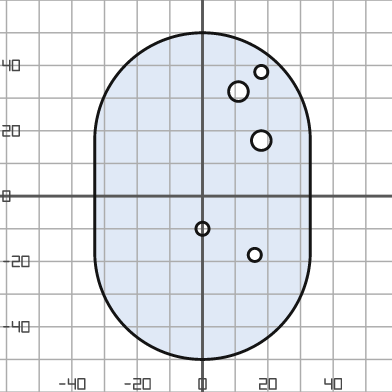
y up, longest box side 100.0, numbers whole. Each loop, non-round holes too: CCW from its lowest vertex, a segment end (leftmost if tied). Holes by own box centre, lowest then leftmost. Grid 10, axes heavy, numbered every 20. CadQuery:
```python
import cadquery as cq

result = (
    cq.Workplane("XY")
    .moveTo(-33.0, -17.0)
    .threePointArc((0.0, -50.0), (33.0, -17.0))
    .lineTo(33.0, 17.0)
    .threePointArc((0.0, 50.0), (-33.0, 17.0))
    .close()
    .moveTo(16.0, -18.0)
    .circle(2.0)
    .moveTo(0.0, -10.0)
    .circle(2.0)
    .moveTo(18.0, 17.0)
    .circle(3.0)
    .moveTo(11.0, 32.0)
    .circle(3.0)
    .moveTo(18.0, 38.0)
    .circle(2.0)
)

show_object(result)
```